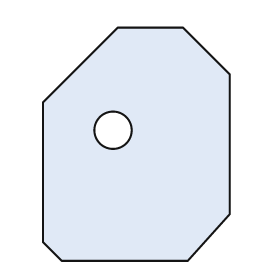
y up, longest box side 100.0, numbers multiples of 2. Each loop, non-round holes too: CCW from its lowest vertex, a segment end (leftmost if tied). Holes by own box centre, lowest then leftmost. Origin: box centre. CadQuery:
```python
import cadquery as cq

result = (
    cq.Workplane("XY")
    .moveTo(-32.0, -50.0)
    .lineTo(22.0, -50.0)
    .lineTo(40.0, -30.0)
    .lineTo(40.0, 30.0)
    .lineTo(20.0, 50.0)
    .lineTo(-8.0, 50.0)
    .lineTo(-40.0, 18.0)
    .lineTo(-40.0, -42.0)
    .close()
    .moveTo(-10.0, 6.0)
    .circle(8.0)
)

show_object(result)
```